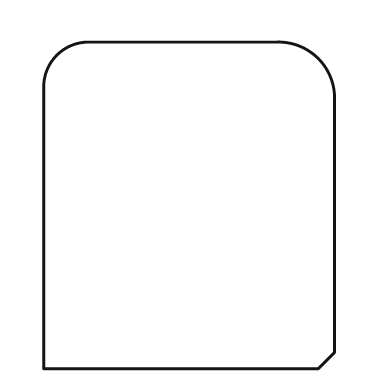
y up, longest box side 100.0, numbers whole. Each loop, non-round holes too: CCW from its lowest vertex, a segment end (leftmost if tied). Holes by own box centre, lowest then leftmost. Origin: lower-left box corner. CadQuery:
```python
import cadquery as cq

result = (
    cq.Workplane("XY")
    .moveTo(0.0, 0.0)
    .lineTo(84.0, 0.0)
    .lineTo(89.0, 5.0)
    .lineTo(89.0, 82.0)
    .threePointArc((84.0, 95.0), (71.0, 100.0))
    .lineTo(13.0, 100.0)
    .threePointArc((4.0, 96.0), (0.0, 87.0))
    .close()
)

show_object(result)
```